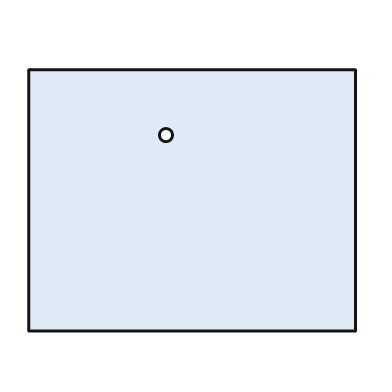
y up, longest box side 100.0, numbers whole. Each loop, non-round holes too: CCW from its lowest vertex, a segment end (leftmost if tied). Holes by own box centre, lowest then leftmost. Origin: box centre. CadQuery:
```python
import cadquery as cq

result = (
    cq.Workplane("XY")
    .moveTo(-50.0, -40.0)
    .lineTo(50.0, -40.0)
    .lineTo(50.0, 40.0)
    .lineTo(-50.0, 40.0)
    .close()
    .moveTo(-8.0, 20.0)
    .circle(2.0)
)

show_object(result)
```